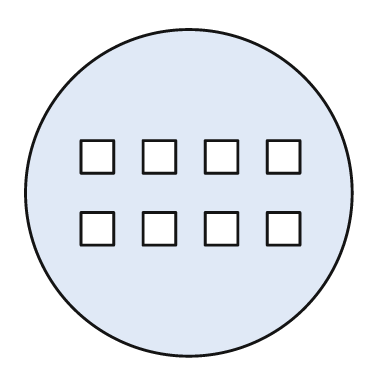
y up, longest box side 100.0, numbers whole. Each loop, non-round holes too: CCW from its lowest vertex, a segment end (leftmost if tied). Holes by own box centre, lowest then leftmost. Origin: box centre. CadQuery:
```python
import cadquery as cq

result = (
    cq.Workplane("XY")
    .moveTo(0.0, 0.0)
    .circle(50.0)
    .moveTo(-33.0, -16.0)
    .lineTo(-23.0, -16.0)
    .lineTo(-23.0, -6.0)
    .lineTo(-33.0, -6.0)
    .close()
    .moveTo(-14.0, -16.0)
    .lineTo(-4.0, -16.0)
    .lineTo(-4.0, -6.0)
    .lineTo(-14.0, -6.0)
    .close()
    .moveTo(5.0, -16.0)
    .lineTo(15.0, -16.0)
    .lineTo(15.0, -6.0)
    .lineTo(5.0, -6.0)
    .close()
    .moveTo(24.0, -16.0)
    .lineTo(34.0, -16.0)
    .lineTo(34.0, -6.0)
    .lineTo(24.0, -6.0)
    .close()
    .moveTo(-33.0, 6.0)
    .lineTo(-23.0, 6.0)
    .lineTo(-23.0, 16.0)
    .lineTo(-33.0, 16.0)
    .close()
    .moveTo(-14.0, 6.0)
    .lineTo(-4.0, 6.0)
    .lineTo(-4.0, 16.0)
    .lineTo(-14.0, 16.0)
    .close()
    .moveTo(5.0, 6.0)
    .lineTo(15.0, 6.0)
    .lineTo(15.0, 16.0)
    .lineTo(5.0, 16.0)
    .close()
    .moveTo(24.0, 6.0)
    .lineTo(34.0, 6.0)
    .lineTo(34.0, 16.0)
    .lineTo(24.0, 16.0)
    .close()
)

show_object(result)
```